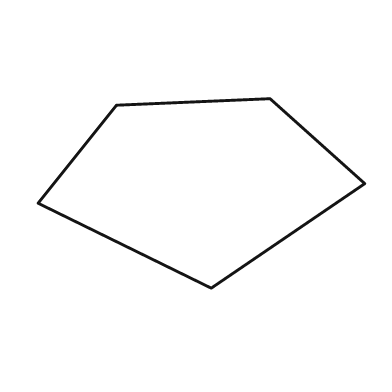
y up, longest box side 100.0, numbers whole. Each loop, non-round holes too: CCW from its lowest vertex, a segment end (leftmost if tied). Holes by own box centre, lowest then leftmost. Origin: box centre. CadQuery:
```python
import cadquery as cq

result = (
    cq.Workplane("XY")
    .moveTo(3.0, -29.0)
    .lineTo(50.0, 3.0)
    .lineTo(21.0, 29.0)
    .lineTo(-26.0, 27.0)
    .lineTo(-50.0, -3.0)
    .close()
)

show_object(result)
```